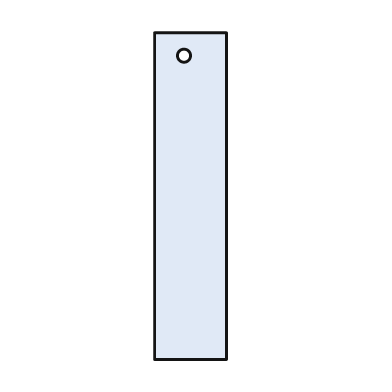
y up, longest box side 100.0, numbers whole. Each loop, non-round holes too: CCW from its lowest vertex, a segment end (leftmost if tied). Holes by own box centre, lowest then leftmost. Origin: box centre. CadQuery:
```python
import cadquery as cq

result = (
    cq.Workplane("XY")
    .moveTo(-11.0, -50.0)
    .lineTo(11.0, -50.0)
    .lineTo(11.0, 50.0)
    .lineTo(-11.0, 50.0)
    .close()
    .moveTo(-2.0, 43.0)
    .circle(2.0)
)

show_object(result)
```